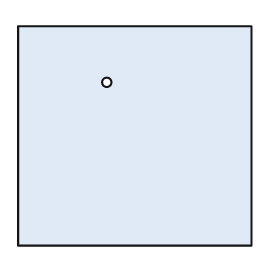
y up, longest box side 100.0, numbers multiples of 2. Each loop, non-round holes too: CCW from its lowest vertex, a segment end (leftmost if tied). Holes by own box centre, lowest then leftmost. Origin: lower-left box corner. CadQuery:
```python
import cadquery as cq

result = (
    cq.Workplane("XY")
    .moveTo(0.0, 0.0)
    .lineTo(100.0, 0.0)
    .lineTo(100.0, 94.0)
    .lineTo(0.0, 94.0)
    .close()
    .moveTo(38.0, 70.0)
    .circle(2.0)
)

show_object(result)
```